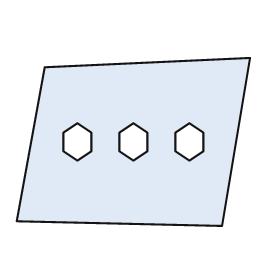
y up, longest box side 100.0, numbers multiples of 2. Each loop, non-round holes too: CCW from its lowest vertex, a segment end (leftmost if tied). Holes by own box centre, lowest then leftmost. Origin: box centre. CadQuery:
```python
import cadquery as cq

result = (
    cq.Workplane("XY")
    .moveTo(38.0, -36.0)
    .lineTo(50.0, 36.0)
    .lineTo(-38.0, 32.0)
    .lineTo(-50.0, -34.0)
    .close()
    .moveTo(-24.0, -8.0)
    .lineTo(-18.0, -4.0)
    .lineTo(-18.0, 4.0)
    .lineTo(-24.0, 8.0)
    .lineTo(-30.0, 4.0)
    .lineTo(-30.0, -4.0)
    .close()
    .moveTo(0.0, -8.0)
    .lineTo(6.0, -4.0)
    .lineTo(6.0, 4.0)
    .lineTo(0.0, 8.0)
    .lineTo(-6.0, 4.0)
    .lineTo(-6.0, -4.0)
    .close()
    .moveTo(24.0, -8.0)
    .lineTo(30.0, -4.0)
    .lineTo(30.0, 4.0)
    .lineTo(24.0, 8.0)
    .lineTo(18.0, 4.0)
    .lineTo(18.0, -4.0)
    .close()
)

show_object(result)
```